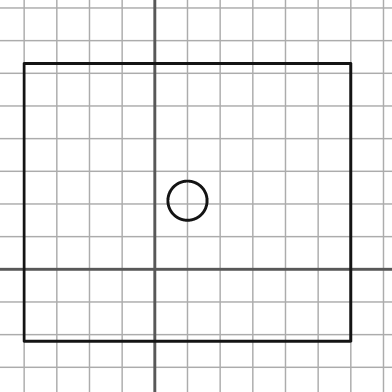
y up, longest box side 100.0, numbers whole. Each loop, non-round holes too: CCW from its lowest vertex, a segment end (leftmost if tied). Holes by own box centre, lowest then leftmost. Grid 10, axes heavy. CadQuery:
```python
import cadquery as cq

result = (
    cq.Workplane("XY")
    .moveTo(-40.0, -22.0)
    .lineTo(60.0, -22.0)
    .lineTo(60.0, 63.0)
    .lineTo(-40.0, 63.0)
    .close()
    .moveTo(10.0, 21.0)
    .circle(6.0)
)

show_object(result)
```